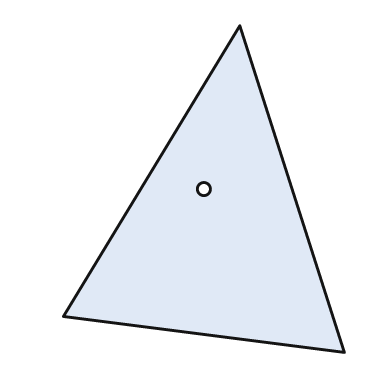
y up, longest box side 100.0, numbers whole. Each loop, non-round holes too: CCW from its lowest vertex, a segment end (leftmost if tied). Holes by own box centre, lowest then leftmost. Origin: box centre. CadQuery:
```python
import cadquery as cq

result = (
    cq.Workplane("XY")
    .moveTo(43.0, -50.0)
    .lineTo(11.0, 50.0)
    .lineTo(-43.0, -39.0)
    .close()
    .moveTo(0.0, 0.0)
    .circle(2.0)
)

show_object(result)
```